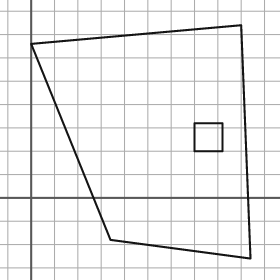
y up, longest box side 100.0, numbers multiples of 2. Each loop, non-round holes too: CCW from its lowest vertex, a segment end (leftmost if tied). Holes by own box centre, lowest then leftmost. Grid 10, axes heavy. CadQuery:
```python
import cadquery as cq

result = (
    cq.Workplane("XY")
    .moveTo(94.0, -26.0)
    .lineTo(90.0, 74.0)
    .lineTo(0.0, 66.0)
    .lineTo(34.0, -18.0)
    .close()
    .moveTo(70.0, 20.0)
    .lineTo(82.0, 20.0)
    .lineTo(82.0, 32.0)
    .lineTo(70.0, 32.0)
    .close()
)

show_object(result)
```